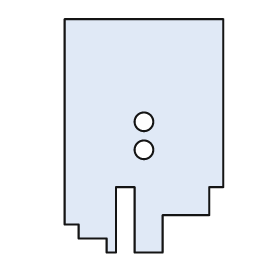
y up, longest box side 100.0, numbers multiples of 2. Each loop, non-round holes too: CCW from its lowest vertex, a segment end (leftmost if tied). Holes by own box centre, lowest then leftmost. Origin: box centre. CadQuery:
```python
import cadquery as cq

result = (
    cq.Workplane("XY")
    .moveTo(-16.0, -50.0)
    .lineTo(-12.0, -50.0)
    .lineTo(-12.0, -22.0)
    .lineTo(-4.0, -22.0)
    .lineTo(-4.0, -50.0)
    .lineTo(8.0, -50.0)
    .lineTo(8.0, -34.0)
    .lineTo(28.0, -34.0)
    .lineTo(28.0, -22.0)
    .lineTo(34.0, -22.0)
    .lineTo(34.0, 50.0)
    .lineTo(-34.0, 50.0)
    .lineTo(-34.0, -38.0)
    .lineTo(-28.0, -38.0)
    .lineTo(-28.0, -44.0)
    .lineTo(-16.0, -44.0)
    .close()
    .moveTo(0.0, -6.0)
    .circle(4.0)
    .moveTo(0.0, 6.0)
    .circle(4.0)
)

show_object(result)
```